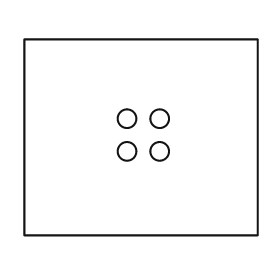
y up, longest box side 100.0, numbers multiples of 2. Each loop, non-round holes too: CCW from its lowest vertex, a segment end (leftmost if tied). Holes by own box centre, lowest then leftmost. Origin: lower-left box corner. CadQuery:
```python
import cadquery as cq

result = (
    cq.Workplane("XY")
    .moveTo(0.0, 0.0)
    .lineTo(100.0, 0.0)
    .lineTo(100.0, 84.0)
    .lineTo(0.0, 84.0)
    .close()
    .moveTo(44.0, 36.0)
    .circle(4.0)
    .moveTo(58.0, 36.0)
    .circle(4.0)
    .moveTo(44.0, 50.0)
    .circle(4.0)
    .moveTo(58.0, 50.0)
    .circle(4.0)
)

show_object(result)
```